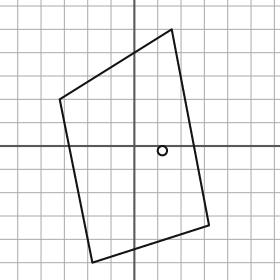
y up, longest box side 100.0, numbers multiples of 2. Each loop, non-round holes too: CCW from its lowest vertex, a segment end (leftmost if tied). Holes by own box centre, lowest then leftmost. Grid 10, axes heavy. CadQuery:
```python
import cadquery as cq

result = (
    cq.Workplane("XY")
    .moveTo(-18.0, -50.0)
    .lineTo(32.0, -34.0)
    .lineTo(16.0, 50.0)
    .lineTo(-32.0, 20.0)
    .close()
    .moveTo(12.0, -2.0)
    .circle(2.0)
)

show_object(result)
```